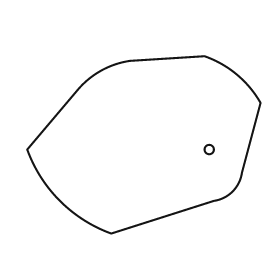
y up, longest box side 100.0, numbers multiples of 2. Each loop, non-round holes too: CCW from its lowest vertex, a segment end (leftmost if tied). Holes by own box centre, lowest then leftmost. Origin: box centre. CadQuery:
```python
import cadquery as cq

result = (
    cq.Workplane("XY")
    .moveTo(-14.0, -38.0)
    .lineTo(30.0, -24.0)
    .threePointArc((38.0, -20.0), (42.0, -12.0))
    .lineTo(50.0, 18.0)
    .threePointArc((40.0, 30.0), (26.0, 38.0))
    .lineTo(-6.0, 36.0)
    .threePointArc((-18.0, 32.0), (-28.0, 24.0))
    .lineTo(-50.0, -2.0)
    .threePointArc((-36.0, -24.0), (-14.0, -38.0))
    .close()
    .moveTo(28.0, -2.0)
    .circle(2.0)
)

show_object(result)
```